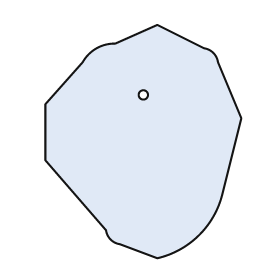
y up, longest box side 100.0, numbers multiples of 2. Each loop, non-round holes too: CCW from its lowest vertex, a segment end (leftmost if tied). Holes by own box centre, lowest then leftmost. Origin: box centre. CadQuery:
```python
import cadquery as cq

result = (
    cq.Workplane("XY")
    .moveTo(6.0, -50.0)
    .threePointArc((24.0, -40.0), (34.0, -22.0))
    .lineTo(42.0, 10.0)
    .lineTo(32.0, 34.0)
    .threePointArc((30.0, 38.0), (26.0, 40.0))
    .lineTo(6.0, 50.0)
    .lineTo(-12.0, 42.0)
    .threePointArc((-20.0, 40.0), (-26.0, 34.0))
    .lineTo(-42.0, 16.0)
    .lineTo(-42.0, -8.0)
    .lineTo(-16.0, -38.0)
    .threePointArc((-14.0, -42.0), (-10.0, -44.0))
    .close()
    .moveTo(0.0, 20.0)
    .circle(2.0)
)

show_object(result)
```